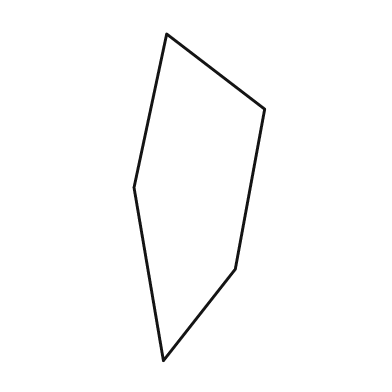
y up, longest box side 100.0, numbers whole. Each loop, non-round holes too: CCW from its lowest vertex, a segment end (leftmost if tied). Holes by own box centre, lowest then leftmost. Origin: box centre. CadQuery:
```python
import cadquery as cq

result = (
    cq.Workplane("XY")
    .moveTo(-11.0, -50.0)
    .lineTo(11.0, -22.0)
    .lineTo(20.0, 27.0)
    .lineTo(-10.0, 50.0)
    .lineTo(-20.0, 3.0)
    .close()
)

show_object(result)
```